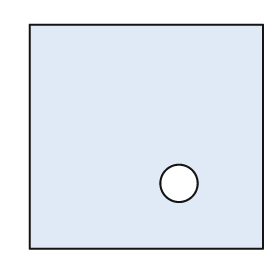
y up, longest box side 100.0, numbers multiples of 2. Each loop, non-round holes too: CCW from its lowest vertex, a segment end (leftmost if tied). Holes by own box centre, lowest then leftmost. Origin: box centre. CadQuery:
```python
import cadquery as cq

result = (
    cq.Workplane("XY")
    .moveTo(-50.0, -48.0)
    .lineTo(50.0, -48.0)
    .lineTo(50.0, 48.0)
    .lineTo(-50.0, 48.0)
    .close()
    .moveTo(14.0, -20.0)
    .circle(8.0)
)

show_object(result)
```